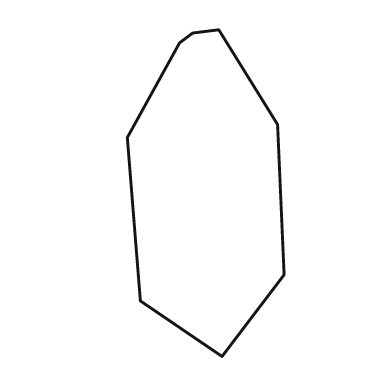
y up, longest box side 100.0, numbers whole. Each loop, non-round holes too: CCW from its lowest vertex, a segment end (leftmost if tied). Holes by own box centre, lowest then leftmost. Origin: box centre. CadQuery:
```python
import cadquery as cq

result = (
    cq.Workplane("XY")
    .moveTo(5.0, -50.0)
    .lineTo(24.0, -25.0)
    .lineTo(22.0, 21.0)
    .lineTo(4.0, 50.0)
    .lineTo(-4.0, 49.0)
    .lineTo(-8.0, 46.0)
    .lineTo(-24.0, 17.0)
    .lineTo(-20.0, -33.0)
    .close()
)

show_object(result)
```